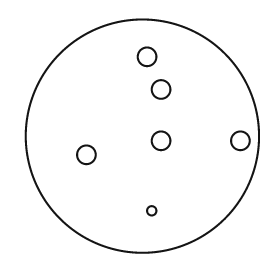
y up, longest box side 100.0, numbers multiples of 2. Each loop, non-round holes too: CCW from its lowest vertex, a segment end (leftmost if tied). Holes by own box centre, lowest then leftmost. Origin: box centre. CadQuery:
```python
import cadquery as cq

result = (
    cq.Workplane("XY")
    .moveTo(0.0, 0.0)
    .circle(50.0)
    .moveTo(4.0, -32.0)
    .circle(2.0)
    .moveTo(-24.0, -8.0)
    .circle(4.0)
    .moveTo(8.0, -2.0)
    .circle(4.0)
    .moveTo(42.0, -2.0)
    .circle(4.0)
    .moveTo(8.0, 20.0)
    .circle(4.0)
    .moveTo(2.0, 34.0)
    .circle(4.0)
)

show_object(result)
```